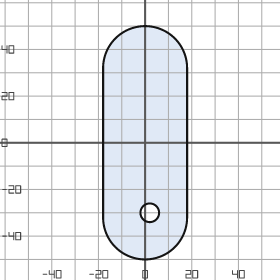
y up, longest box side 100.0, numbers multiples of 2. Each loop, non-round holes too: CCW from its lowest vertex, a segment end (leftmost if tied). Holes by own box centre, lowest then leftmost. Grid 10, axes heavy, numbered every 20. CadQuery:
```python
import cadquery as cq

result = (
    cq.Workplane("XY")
    .moveTo(-18.0, -32.0)
    .threePointArc((0.0, -50.0), (18.0, -32.0))
    .lineTo(18.0, 32.0)
    .threePointArc((0.0, 50.0), (-18.0, 32.0))
    .close()
    .moveTo(2.0, -30.0)
    .circle(4.0)
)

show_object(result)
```